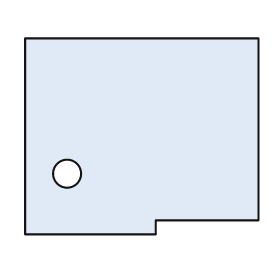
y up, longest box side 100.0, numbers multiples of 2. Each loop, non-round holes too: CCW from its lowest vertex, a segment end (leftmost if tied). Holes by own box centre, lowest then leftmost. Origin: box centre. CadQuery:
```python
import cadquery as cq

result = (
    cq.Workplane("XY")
    .moveTo(-50.0, -42.0)
    .lineTo(6.0, -42.0)
    .lineTo(6.0, -36.0)
    .lineTo(50.0, -36.0)
    .lineTo(50.0, 42.0)
    .lineTo(-50.0, 42.0)
    .close()
    .moveTo(-32.0, -16.0)
    .circle(6.0)
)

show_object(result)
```